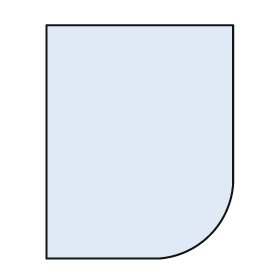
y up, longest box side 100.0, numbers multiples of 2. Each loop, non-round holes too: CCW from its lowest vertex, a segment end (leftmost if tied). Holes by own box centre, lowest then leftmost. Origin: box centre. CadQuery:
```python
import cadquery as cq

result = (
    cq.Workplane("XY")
    .moveTo(-40.0, -50.0)
    .lineTo(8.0, -50.0)
    .threePointArc((30.0, -40.0), (40.0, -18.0))
    .lineTo(40.0, 50.0)
    .lineTo(-40.0, 50.0)
    .close()
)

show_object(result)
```